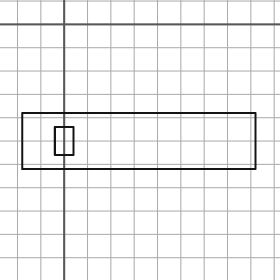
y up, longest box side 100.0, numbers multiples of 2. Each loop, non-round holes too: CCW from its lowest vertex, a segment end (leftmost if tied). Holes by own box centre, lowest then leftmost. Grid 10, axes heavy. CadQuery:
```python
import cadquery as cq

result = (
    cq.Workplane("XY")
    .moveTo(-18.0, -62.0)
    .lineTo(82.0, -62.0)
    .lineTo(82.0, -38.0)
    .lineTo(-18.0, -38.0)
    .close()
    .moveTo(-4.0, -56.0)
    .lineTo(4.0, -56.0)
    .lineTo(4.0, -44.0)
    .lineTo(-4.0, -44.0)
    .close()
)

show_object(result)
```